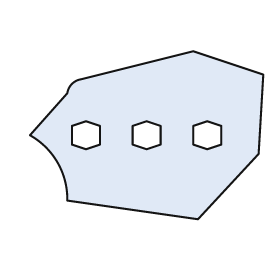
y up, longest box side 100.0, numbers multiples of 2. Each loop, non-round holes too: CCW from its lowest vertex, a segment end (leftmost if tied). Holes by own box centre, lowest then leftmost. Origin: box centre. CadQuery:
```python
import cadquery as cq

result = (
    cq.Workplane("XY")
    .moveTo(22.0, -36.0)
    .lineTo(48.0, -8.0)
    .lineTo(50.0, 26.0)
    .lineTo(20.0, 36.0)
    .lineTo(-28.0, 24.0)
    .threePointArc((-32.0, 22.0), (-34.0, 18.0))
    .lineTo(-50.0, 0.0)
    .threePointArc((-38.0, -12.0), (-34.0, -28.0))
    .close()
    .moveTo(-26.0, -6.0)
    .lineTo(-20.0, -4.0)
    .lineTo(-20.0, 4.0)
    .lineTo(-26.0, 6.0)
    .lineTo(-32.0, 4.0)
    .lineTo(-32.0, -4.0)
    .close()
    .moveTo(0.0, -6.0)
    .lineTo(6.0, -4.0)
    .lineTo(6.0, 4.0)
    .lineTo(0.0, 6.0)
    .lineTo(-6.0, 4.0)
    .lineTo(-6.0, -4.0)
    .close()
    .moveTo(26.0, -6.0)
    .lineTo(32.0, -4.0)
    .lineTo(32.0, 4.0)
    .lineTo(26.0, 6.0)
    .lineTo(20.0, 4.0)
    .lineTo(20.0, -4.0)
    .close()
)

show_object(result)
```